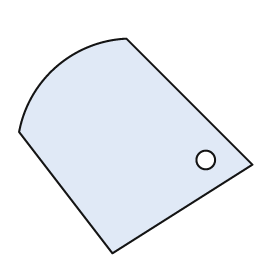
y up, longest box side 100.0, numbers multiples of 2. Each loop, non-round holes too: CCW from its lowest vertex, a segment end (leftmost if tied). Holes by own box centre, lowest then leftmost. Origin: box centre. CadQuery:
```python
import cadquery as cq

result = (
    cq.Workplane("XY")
    .moveTo(-10.0, -46.0)
    .lineTo(50.0, -8.0)
    .lineTo(-4.0, 46.0)
    .threePointArc((-34.0, 34.0), (-50.0, 6.0))
    .close()
    .moveTo(30.0, -6.0)
    .circle(4.0)
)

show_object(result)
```